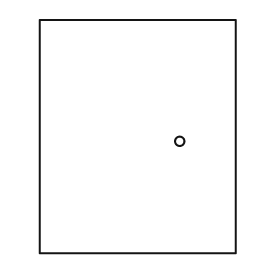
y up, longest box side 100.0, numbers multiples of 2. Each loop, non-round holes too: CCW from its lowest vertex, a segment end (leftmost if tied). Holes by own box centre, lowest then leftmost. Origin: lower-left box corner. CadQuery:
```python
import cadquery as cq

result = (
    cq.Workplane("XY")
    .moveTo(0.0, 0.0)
    .lineTo(84.0, 0.0)
    .lineTo(84.0, 100.0)
    .lineTo(0.0, 100.0)
    .close()
    .moveTo(60.0, 48.0)
    .circle(2.0)
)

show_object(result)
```